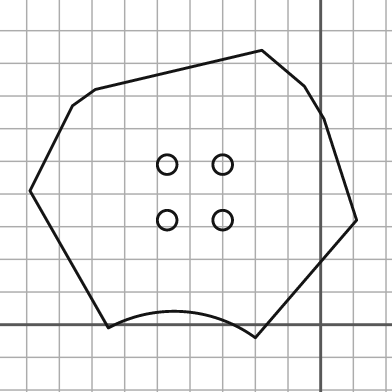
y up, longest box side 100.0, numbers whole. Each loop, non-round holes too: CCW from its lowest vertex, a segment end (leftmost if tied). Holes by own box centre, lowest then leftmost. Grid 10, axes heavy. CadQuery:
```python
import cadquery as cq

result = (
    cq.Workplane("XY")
    .moveTo(-20.0, -4.0)
    .lineTo(11.0, 32.0)
    .lineTo(1.0, 63.0)
    .lineTo(-5.0, 73.0)
    .lineTo(-18.0, 84.0)
    .lineTo(-69.0, 72.0)
    .lineTo(-76.0, 67.0)
    .lineTo(-89.0, 41.0)
    .lineTo(-65.0, -1.0)
    .threePointArc((-42.0, 4.0), (-20.0, -4.0))
    .close()
    .moveTo(-47.0, 32.0)
    .circle(3.0)
    .moveTo(-30.0, 32.0)
    .circle(3.0)
    .moveTo(-47.0, 49.0)
    .circle(3.0)
    .moveTo(-30.0, 49.0)
    .circle(3.0)
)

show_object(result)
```